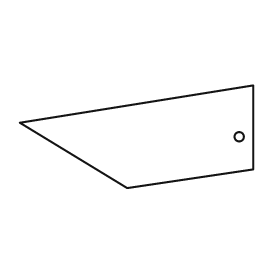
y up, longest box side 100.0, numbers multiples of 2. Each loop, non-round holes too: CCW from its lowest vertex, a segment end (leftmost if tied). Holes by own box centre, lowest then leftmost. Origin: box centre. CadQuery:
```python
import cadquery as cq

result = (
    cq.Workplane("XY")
    .moveTo(-4.0, -22.0)
    .lineTo(50.0, -14.0)
    .lineTo(50.0, 22.0)
    .lineTo(-50.0, 6.0)
    .close()
    .moveTo(44.0, 0.0)
    .circle(2.0)
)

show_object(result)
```